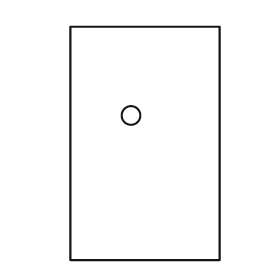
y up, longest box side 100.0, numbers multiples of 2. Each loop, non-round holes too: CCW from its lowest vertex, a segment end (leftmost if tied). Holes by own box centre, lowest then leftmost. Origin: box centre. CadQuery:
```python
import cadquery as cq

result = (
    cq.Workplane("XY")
    .moveTo(-32.0, -50.0)
    .lineTo(32.0, -50.0)
    .lineTo(32.0, 50.0)
    .lineTo(-32.0, 50.0)
    .close()
    .moveTo(-6.0, 12.0)
    .circle(4.0)
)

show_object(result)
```